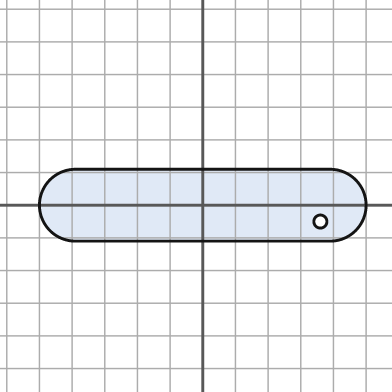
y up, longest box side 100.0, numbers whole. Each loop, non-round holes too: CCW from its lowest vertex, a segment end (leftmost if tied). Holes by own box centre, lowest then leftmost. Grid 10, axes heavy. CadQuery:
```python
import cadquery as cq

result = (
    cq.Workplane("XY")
    .moveTo(-39.0, -11.0)
    .lineTo(39.0, -11.0)
    .threePointArc((50.0, 0.0), (39.0, 11.0))
    .lineTo(-39.0, 11.0)
    .threePointArc((-50.0, 0.0), (-39.0, -11.0))
    .close()
    .moveTo(36.0, -5.0)
    .circle(2.0)
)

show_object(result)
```